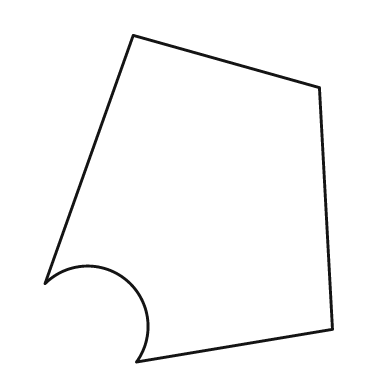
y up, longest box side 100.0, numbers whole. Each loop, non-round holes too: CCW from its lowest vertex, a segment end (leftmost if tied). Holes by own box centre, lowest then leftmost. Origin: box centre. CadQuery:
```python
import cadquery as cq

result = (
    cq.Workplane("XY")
    .moveTo(-16.0, -50.0)
    .lineTo(44.0, -40.0)
    .lineTo(40.0, 34.0)
    .lineTo(-17.0, 50.0)
    .lineTo(-44.0, -26.0)
    .threePointArc((-19.0, -25.0), (-16.0, -50.0))
    .close()
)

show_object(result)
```